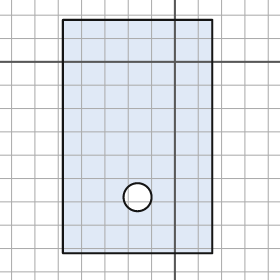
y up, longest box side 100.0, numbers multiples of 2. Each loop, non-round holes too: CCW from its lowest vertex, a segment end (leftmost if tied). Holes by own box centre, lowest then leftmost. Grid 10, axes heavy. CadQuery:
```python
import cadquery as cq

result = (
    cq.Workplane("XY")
    .moveTo(-48.0, -82.0)
    .lineTo(16.0, -82.0)
    .lineTo(16.0, 18.0)
    .lineTo(-48.0, 18.0)
    .close()
    .moveTo(-16.0, -58.0)
    .circle(6.0)
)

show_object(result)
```